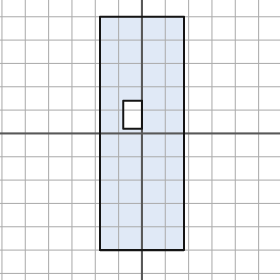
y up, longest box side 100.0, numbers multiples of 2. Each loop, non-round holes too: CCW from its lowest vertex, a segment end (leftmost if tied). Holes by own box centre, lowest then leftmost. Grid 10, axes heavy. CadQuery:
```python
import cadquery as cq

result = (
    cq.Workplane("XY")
    .moveTo(-18.0, -50.0)
    .lineTo(18.0, -50.0)
    .lineTo(18.0, 50.0)
    .lineTo(-18.0, 50.0)
    .close()
    .moveTo(-8.0, 2.0)
    .lineTo(0.0, 2.0)
    .lineTo(0.0, 14.0)
    .lineTo(-8.0, 14.0)
    .close()
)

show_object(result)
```